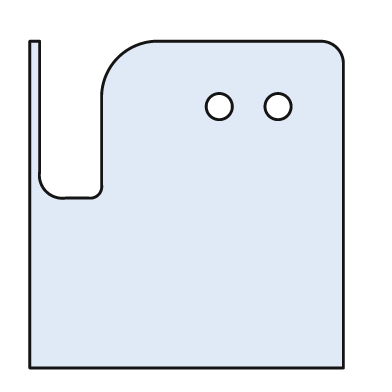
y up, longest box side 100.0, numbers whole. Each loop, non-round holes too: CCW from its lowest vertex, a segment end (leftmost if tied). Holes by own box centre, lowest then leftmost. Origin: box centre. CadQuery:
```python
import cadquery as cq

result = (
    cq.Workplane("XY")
    .moveTo(-48.0, -50.0)
    .lineTo(48.0, -50.0)
    .lineTo(48.0, 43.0)
    .threePointArc((46.0, 48.0), (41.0, 50.0))
    .lineTo(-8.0, 50.0)
    .threePointArc((-21.0, 45.0), (-26.0, 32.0))
    .lineTo(-26.0, 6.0)
    .threePointArc((-27.0, 3.0), (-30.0, 2.0))
    .lineTo(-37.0, 2.0)
    .threePointArc((-43.0, 4.0), (-45.0, 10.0))
    .lineTo(-45.0, 50.0)
    .lineTo(-48.0, 50.0)
    .close()
    .moveTo(10.0, 30.0)
    .circle(4.0)
    .moveTo(28.0, 30.0)
    .circle(4.0)
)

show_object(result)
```